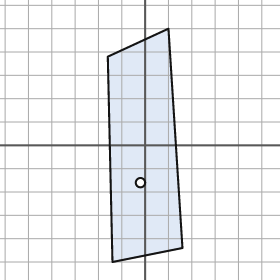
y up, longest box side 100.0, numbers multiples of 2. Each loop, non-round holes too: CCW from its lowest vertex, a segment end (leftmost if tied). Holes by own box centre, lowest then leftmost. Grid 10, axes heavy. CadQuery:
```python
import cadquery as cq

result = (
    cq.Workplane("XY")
    .moveTo(-14.0, -50.0)
    .lineTo(16.0, -44.0)
    .lineTo(10.0, 50.0)
    .lineTo(-16.0, 38.0)
    .close()
    .moveTo(-2.0, -16.0)
    .circle(2.0)
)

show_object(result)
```